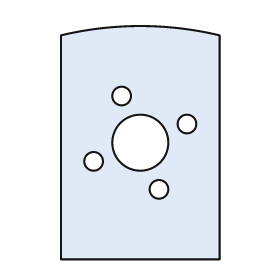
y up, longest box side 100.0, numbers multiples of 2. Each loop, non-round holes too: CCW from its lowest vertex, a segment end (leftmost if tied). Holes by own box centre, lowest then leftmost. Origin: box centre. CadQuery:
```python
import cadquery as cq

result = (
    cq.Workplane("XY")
    .moveTo(-34.0, -50.0)
    .lineTo(34.0, -50.0)
    .lineTo(34.0, 46.0)
    .threePointArc((0.0, 50.0), (-34.0, 46.0))
    .close()
    .moveTo(8.0, -20.0)
    .circle(4.0)
    .moveTo(-20.0, -8.0)
    .circle(4.0)
    .moveTo(0.0, 0.0)
    .circle(12.0)
    .moveTo(20.0, 8.0)
    .circle(4.0)
    .moveTo(-8.0, 20.0)
    .circle(4.0)
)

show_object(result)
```